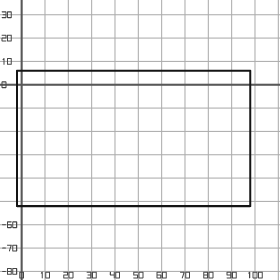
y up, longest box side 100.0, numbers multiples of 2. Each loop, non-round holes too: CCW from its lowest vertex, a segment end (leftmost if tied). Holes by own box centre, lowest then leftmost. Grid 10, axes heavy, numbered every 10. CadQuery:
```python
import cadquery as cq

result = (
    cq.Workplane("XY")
    .moveTo(-2.0, -52.0)
    .lineTo(98.0, -52.0)
    .lineTo(98.0, 6.0)
    .lineTo(-2.0, 6.0)
    .close()
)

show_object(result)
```